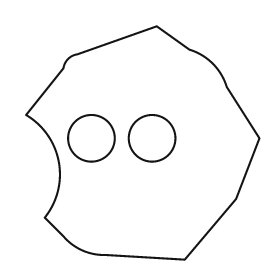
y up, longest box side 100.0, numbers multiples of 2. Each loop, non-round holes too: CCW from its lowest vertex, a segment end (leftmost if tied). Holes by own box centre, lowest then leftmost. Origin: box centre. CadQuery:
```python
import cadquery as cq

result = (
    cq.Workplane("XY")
    .moveTo(18.0, -50.0)
    .lineTo(40.0, -24.0)
    .lineTo(50.0, 2.0)
    .lineTo(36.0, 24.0)
    .threePointArc((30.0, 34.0), (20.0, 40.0))
    .lineTo(6.0, 50.0)
    .lineTo(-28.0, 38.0)
    .threePointArc((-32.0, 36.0), (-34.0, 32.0))
    .lineTo(-50.0, 12.0)
    .threePointArc((-36.0, -8.0), (-42.0, -32.0))
    .lineTo(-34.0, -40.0)
    .threePointArc((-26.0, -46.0), (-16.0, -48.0))
    .close()
    .moveTo(-22.0, 2.0)
    .circle(10.0)
    .moveTo(4.0, 2.0)
    .circle(10.0)
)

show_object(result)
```